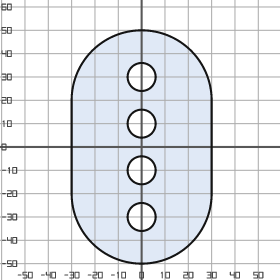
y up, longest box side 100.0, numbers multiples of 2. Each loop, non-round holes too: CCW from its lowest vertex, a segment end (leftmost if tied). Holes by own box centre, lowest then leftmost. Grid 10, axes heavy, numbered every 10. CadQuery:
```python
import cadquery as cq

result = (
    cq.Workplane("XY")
    .moveTo(-30.0, -20.0)
    .threePointArc((0.0, -50.0), (30.0, -20.0))
    .lineTo(30.0, 20.0)
    .threePointArc((0.0, 50.0), (-30.0, 20.0))
    .close()
    .moveTo(0.0, -30.0)
    .circle(6.0)
    .moveTo(0.0, -10.0)
    .circle(6.0)
    .moveTo(0.0, 10.0)
    .circle(6.0)
    .moveTo(0.0, 30.0)
    .circle(6.0)
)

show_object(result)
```